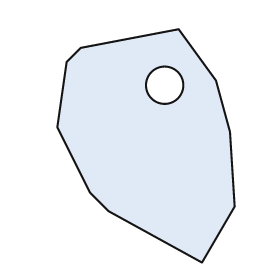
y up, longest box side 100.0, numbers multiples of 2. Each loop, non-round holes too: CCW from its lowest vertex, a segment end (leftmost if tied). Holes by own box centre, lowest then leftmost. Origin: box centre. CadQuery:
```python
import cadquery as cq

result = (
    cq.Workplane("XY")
    .moveTo(24.0, -50.0)
    .lineTo(38.0, -26.0)
    .lineTo(36.0, 6.0)
    .lineTo(30.0, 28.0)
    .lineTo(14.0, 50.0)
    .lineTo(-28.0, 42.0)
    .lineTo(-34.0, 36.0)
    .lineTo(-38.0, 8.0)
    .lineTo(-24.0, -20.0)
    .lineTo(-16.0, -28.0)
    .close()
    .moveTo(8.0, 26.0)
    .circle(8.0)
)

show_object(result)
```